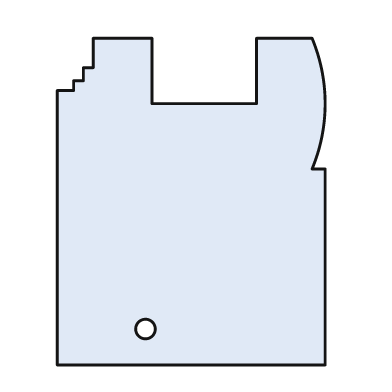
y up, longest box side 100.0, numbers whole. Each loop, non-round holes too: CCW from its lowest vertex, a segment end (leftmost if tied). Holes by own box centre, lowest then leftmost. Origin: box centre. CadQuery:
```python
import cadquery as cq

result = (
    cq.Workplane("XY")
    .moveTo(-41.0, -50.0)
    .lineTo(41.0, -50.0)
    .lineTo(41.0, 10.0)
    .lineTo(37.0, 10.0)
    .threePointArc((41.0, 30.0), (37.0, 50.0))
    .lineTo(20.0, 50.0)
    .lineTo(20.0, 30.0)
    .lineTo(-12.0, 30.0)
    .lineTo(-12.0, 50.0)
    .lineTo(-30.0, 50.0)
    .lineTo(-30.0, 41.0)
    .lineTo(-33.0, 41.0)
    .lineTo(-33.0, 37.0)
    .lineTo(-36.0, 37.0)
    .lineTo(-36.0, 34.0)
    .lineTo(-41.0, 34.0)
    .close()
    .moveTo(-14.0, -39.0)
    .circle(3.0)
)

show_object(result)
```